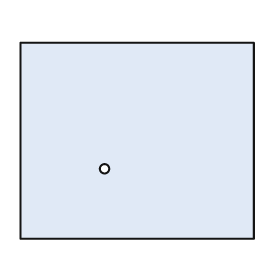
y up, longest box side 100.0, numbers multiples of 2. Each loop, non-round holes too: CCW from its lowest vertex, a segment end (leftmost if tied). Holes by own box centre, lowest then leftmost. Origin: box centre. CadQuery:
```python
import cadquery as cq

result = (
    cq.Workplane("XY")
    .moveTo(-50.0, -42.0)
    .lineTo(50.0, -42.0)
    .lineTo(50.0, 42.0)
    .lineTo(-50.0, 42.0)
    .close()
    .moveTo(-14.0, -12.0)
    .circle(2.0)
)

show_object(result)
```